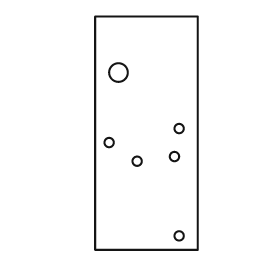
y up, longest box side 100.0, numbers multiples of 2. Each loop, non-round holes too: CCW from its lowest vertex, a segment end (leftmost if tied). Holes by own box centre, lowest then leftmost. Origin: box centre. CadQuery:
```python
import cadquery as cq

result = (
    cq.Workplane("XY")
    .moveTo(-22.0, -50.0)
    .lineTo(22.0, -50.0)
    .lineTo(22.0, 50.0)
    .lineTo(-22.0, 50.0)
    .close()
    .moveTo(14.0, -44.0)
    .circle(2.0)
    .moveTo(-4.0, -12.0)
    .circle(2.0)
    .moveTo(12.0, -10.0)
    .circle(2.0)
    .moveTo(-16.0, -4.0)
    .circle(2.0)
    .moveTo(14.0, 2.0)
    .circle(2.0)
    .moveTo(-12.0, 26.0)
    .circle(4.0)
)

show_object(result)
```